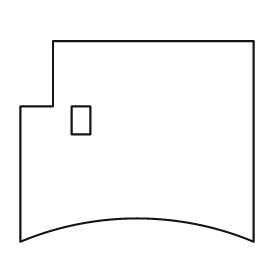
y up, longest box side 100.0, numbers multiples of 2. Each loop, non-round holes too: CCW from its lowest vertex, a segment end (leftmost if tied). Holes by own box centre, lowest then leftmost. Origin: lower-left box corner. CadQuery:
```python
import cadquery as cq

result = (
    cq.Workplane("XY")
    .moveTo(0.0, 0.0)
    .threePointArc((50.0, 10.0), (100.0, 0.0))
    .lineTo(100.0, 86.0)
    .lineTo(14.0, 86.0)
    .lineTo(14.0, 58.0)
    .lineTo(0.0, 58.0)
    .close()
    .moveTo(22.0, 46.0)
    .lineTo(30.0, 46.0)
    .lineTo(30.0, 58.0)
    .lineTo(22.0, 58.0)
    .close()
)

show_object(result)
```